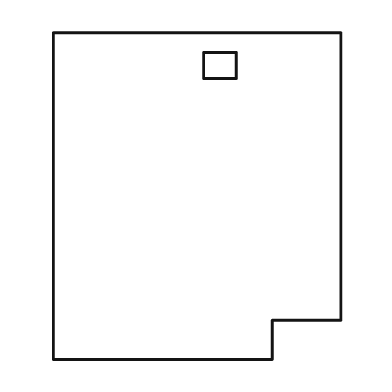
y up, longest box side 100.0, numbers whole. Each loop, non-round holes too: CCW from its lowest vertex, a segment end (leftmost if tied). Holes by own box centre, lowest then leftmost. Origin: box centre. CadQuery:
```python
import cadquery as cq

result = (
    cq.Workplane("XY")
    .moveTo(-44.0, -50.0)
    .lineTo(23.0, -50.0)
    .lineTo(23.0, -38.0)
    .lineTo(44.0, -38.0)
    .lineTo(44.0, 50.0)
    .lineTo(-44.0, 50.0)
    .close()
    .moveTo(2.0, 36.0)
    .lineTo(12.0, 36.0)
    .lineTo(12.0, 44.0)
    .lineTo(2.0, 44.0)
    .close()
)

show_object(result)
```